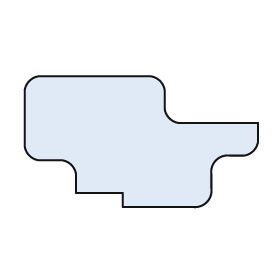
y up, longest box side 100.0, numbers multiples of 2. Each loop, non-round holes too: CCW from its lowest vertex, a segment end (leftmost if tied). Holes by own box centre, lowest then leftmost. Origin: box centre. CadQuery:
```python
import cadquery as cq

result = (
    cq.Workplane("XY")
    .moveTo(-8.0, -28.0)
    .lineTo(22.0, -28.0)
    .threePointArc((28.0, -26.0), (30.0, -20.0))
    .lineTo(30.0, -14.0)
    .threePointArc((32.0, -8.0), (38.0, -6.0))
    .lineTo(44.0, -6.0)
    .threePointArc((48.0, -4.0), (50.0, 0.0))
    .lineTo(50.0, 8.0)
    .lineTo(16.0, 8.0)
    .threePointArc((12.0, 10.0), (10.0, 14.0))
    .lineTo(10.0, 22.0)
    .threePointArc((8.0, 26.0), (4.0, 28.0))
    .lineTo(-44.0, 28.0)
    .threePointArc((-48.0, 26.0), (-50.0, 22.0))
    .lineTo(-50.0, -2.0)
    .threePointArc((-48.0, -6.0), (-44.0, -8.0))
    .lineTo(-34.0, -8.0)
    .threePointArc((-30.0, -10.0), (-28.0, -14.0))
    .lineTo(-28.0, -22.0)
    .lineTo(-8.0, -22.0)
    .close()
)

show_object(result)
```